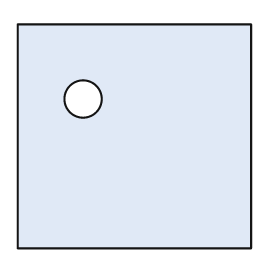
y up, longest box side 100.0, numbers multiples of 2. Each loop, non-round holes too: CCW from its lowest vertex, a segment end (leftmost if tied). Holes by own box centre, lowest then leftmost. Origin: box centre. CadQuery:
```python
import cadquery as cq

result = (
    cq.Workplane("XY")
    .moveTo(-50.0, -48.0)
    .lineTo(50.0, -48.0)
    .lineTo(50.0, 48.0)
    .lineTo(-50.0, 48.0)
    .close()
    .moveTo(-22.0, 16.0)
    .circle(8.0)
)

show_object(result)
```